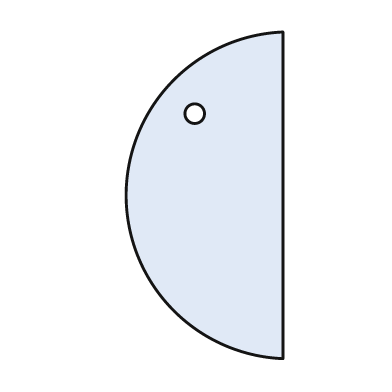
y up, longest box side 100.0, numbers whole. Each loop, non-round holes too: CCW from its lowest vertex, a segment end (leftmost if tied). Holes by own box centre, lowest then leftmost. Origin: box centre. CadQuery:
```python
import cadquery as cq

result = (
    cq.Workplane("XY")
    .moveTo(24.0, -50.0)
    .lineTo(24.0, 50.0)
    .threePointArc((-24.0, 0.0), (24.0, -50.0))
    .close()
    .moveTo(-3.0, 25.0)
    .circle(3.0)
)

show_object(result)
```